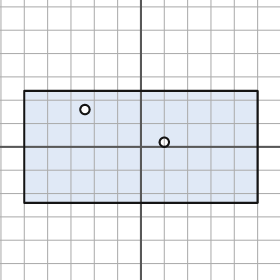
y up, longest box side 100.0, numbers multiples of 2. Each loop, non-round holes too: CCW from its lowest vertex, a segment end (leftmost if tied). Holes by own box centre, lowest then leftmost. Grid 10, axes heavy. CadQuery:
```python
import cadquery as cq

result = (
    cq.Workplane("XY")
    .moveTo(-50.0, -24.0)
    .lineTo(50.0, -24.0)
    .lineTo(50.0, 24.0)
    .lineTo(-50.0, 24.0)
    .close()
    .moveTo(10.0, 2.0)
    .circle(2.0)
    .moveTo(-24.0, 16.0)
    .circle(2.0)
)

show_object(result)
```